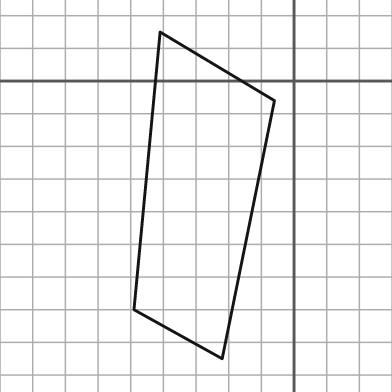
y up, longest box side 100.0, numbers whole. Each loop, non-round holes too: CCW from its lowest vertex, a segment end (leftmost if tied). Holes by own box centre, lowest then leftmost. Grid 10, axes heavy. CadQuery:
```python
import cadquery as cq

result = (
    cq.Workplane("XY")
    .moveTo(-22.0, -85.0)
    .lineTo(-6.0, -6.0)
    .lineTo(-41.0, 15.0)
    .lineTo(-49.0, -70.0)
    .close()
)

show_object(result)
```